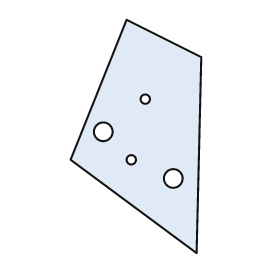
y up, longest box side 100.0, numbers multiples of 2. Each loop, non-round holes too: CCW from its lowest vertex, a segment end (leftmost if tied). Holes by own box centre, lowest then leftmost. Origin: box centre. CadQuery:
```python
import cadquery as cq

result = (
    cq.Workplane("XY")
    .moveTo(26.0, -50.0)
    .lineTo(28.0, 34.0)
    .lineTo(-4.0, 50.0)
    .lineTo(-28.0, -10.0)
    .close()
    .moveTo(16.0, -18.0)
    .circle(4.0)
    .moveTo(-2.0, -10.0)
    .circle(2.0)
    .moveTo(-14.0, 2.0)
    .circle(4.0)
    .moveTo(4.0, 16.0)
    .circle(2.0)
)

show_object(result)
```